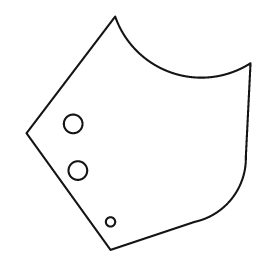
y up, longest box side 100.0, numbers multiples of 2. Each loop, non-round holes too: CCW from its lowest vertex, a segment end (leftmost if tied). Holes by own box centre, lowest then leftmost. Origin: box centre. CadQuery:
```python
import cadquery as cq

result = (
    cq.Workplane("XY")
    .moveTo(-12.0, -50.0)
    .lineTo(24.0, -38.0)
    .threePointArc((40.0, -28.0), (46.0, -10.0))
    .lineTo(48.0, 30.0)
    .threePointArc((14.0, 26.0), (-10.0, 50.0))
    .lineTo(-48.0, 0.0)
    .close()
    .moveTo(-12.0, -38.0)
    .circle(2.0)
    .moveTo(-26.0, -16.0)
    .circle(4.0)
    .moveTo(-28.0, 4.0)
    .circle(4.0)
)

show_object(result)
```